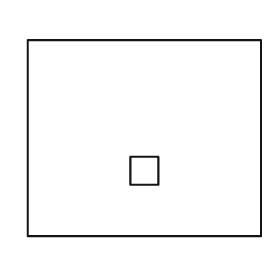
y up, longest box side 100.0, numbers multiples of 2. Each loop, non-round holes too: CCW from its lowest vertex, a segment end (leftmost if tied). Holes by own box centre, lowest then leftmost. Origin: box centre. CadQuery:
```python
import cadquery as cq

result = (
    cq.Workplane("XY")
    .moveTo(-50.0, -42.0)
    .lineTo(50.0, -42.0)
    .lineTo(50.0, 42.0)
    .lineTo(-50.0, 42.0)
    .close()
    .moveTo(-6.0, -20.0)
    .lineTo(6.0, -20.0)
    .lineTo(6.0, -8.0)
    .lineTo(-6.0, -8.0)
    .close()
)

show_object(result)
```